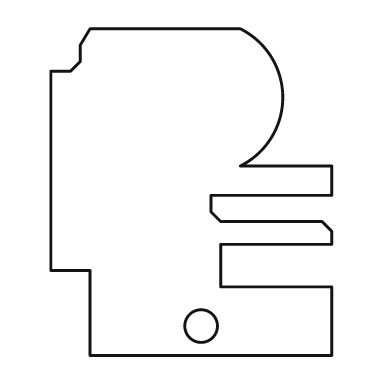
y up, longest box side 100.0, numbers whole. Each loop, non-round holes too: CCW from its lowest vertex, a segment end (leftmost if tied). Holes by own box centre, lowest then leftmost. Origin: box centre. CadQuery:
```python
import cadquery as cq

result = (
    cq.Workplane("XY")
    .moveTo(-31.0, -50.0)
    .lineTo(43.0, -50.0)
    .lineTo(43.0, -29.0)
    .lineTo(9.0, -29.0)
    .lineTo(9.0, -16.0)
    .lineTo(43.0, -16.0)
    .lineTo(43.0, -12.0)
    .lineTo(40.0, -9.0)
    .lineTo(9.0, -9.0)
    .lineTo(6.0, -6.0)
    .lineTo(6.0, -1.0)
    .lineTo(43.0, -1.0)
    .lineTo(43.0, 8.0)
    .lineTo(15.0, 8.0)
    .threePointArc((28.0, 29.0), (15.0, 50.0))
    .lineTo(-31.0, 50.0)
    .lineTo(-34.0, 45.0)
    .lineTo(-34.0, 40.0)
    .lineTo(-37.0, 37.0)
    .lineTo(-43.0, 37.0)
    .lineTo(-43.0, -24.0)
    .lineTo(-31.0, -24.0)
    .close()
    .moveTo(3.0, -41.0)
    .circle(5.0)
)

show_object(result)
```